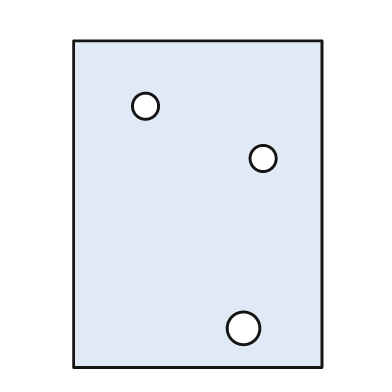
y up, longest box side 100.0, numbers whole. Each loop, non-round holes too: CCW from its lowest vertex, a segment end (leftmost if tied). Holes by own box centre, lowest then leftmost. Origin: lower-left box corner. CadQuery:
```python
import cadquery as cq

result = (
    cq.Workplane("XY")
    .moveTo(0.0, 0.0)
    .lineTo(76.0, 0.0)
    .lineTo(76.0, 100.0)
    .lineTo(0.0, 100.0)
    .close()
    .moveTo(52.0, 12.0)
    .circle(5.0)
    .moveTo(58.0, 64.0)
    .circle(4.0)
    .moveTo(22.0, 80.0)
    .circle(4.0)
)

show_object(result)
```